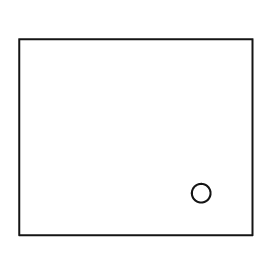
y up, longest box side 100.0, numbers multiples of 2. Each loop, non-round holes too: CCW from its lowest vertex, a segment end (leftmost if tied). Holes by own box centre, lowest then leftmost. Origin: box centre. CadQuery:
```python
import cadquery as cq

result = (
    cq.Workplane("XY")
    .moveTo(-50.0, -42.0)
    .lineTo(50.0, -42.0)
    .lineTo(50.0, 42.0)
    .lineTo(-50.0, 42.0)
    .close()
    .moveTo(28.0, -24.0)
    .circle(4.0)
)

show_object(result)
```